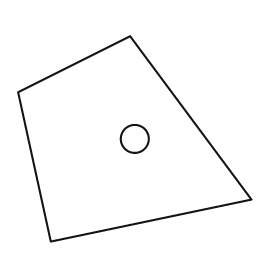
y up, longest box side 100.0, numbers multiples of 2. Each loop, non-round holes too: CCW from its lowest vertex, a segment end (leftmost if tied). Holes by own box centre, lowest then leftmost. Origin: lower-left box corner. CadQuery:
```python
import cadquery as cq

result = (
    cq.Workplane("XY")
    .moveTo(14.0, 0.0)
    .lineTo(100.0, 18.0)
    .lineTo(48.0, 88.0)
    .lineTo(0.0, 64.0)
    .close()
    .moveTo(50.0, 44.0)
    .circle(6.0)
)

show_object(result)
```